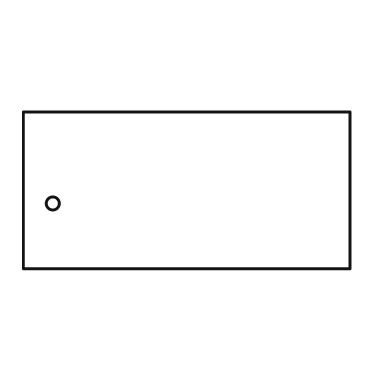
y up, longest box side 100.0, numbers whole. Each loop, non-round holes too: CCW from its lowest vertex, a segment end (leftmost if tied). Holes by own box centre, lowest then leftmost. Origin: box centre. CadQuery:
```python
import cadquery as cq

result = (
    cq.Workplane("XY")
    .moveTo(-50.0, -24.0)
    .lineTo(50.0, -24.0)
    .lineTo(50.0, 24.0)
    .lineTo(-50.0, 24.0)
    .close()
    .moveTo(-41.0, -4.0)
    .circle(2.0)
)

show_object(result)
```